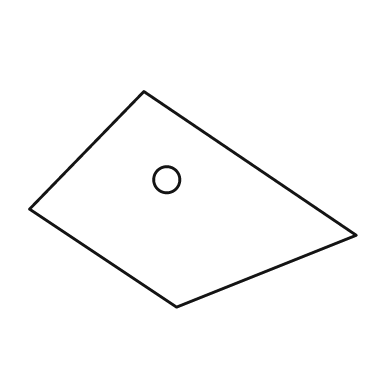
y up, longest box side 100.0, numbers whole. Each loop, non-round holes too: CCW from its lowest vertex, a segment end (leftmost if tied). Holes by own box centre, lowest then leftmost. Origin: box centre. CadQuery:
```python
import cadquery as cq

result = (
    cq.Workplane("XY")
    .moveTo(-5.0, -33.0)
    .lineTo(50.0, -11.0)
    .lineTo(-15.0, 33.0)
    .lineTo(-50.0, -3.0)
    .close()
    .moveTo(-8.0, 6.0)
    .circle(4.0)
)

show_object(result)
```